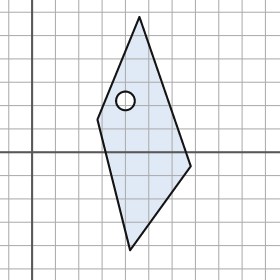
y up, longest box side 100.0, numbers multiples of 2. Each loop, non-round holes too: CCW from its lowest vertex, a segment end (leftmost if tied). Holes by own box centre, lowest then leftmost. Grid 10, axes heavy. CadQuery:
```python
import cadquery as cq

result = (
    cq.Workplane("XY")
    .moveTo(42.0, -42.0)
    .lineTo(68.0, -6.0)
    .lineTo(46.0, 58.0)
    .lineTo(28.0, 14.0)
    .close()
    .moveTo(40.0, 22.0)
    .circle(4.0)
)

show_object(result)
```